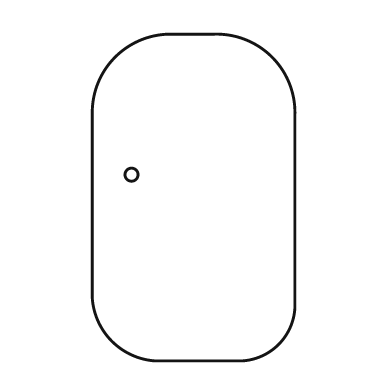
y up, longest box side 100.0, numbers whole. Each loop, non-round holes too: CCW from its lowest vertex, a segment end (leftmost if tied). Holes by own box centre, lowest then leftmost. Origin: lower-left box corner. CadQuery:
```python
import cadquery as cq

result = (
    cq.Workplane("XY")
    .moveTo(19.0, 0.0)
    .lineTo(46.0, 0.0)
    .threePointArc((57.0, 5.0), (62.0, 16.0))
    .lineTo(62.0, 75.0)
    .threePointArc((55.0, 93.0), (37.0, 100.0))
    .lineTo(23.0, 100.0)
    .threePointArc((7.0, 93.0), (0.0, 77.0))
    .lineTo(0.0, 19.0)
    .threePointArc((6.0, 6.0), (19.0, 0.0))
    .close()
    .moveTo(12.0, 57.0)
    .circle(2.0)
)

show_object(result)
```